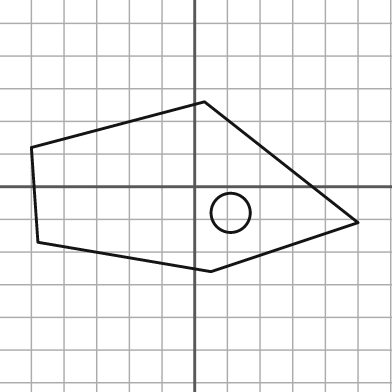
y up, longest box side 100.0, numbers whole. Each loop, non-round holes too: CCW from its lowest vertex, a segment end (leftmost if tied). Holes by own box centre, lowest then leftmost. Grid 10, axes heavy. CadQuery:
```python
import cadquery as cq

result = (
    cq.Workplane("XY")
    .moveTo(5.0, -26.0)
    .lineTo(50.0, -11.0)
    .lineTo(3.0, 26.0)
    .lineTo(-50.0, 12.0)
    .lineTo(-48.0, -17.0)
    .close()
    .moveTo(11.0, -8.0)
    .circle(6.0)
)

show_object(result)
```